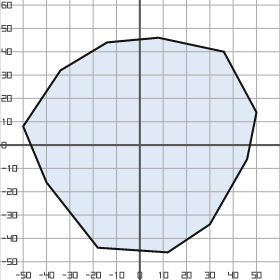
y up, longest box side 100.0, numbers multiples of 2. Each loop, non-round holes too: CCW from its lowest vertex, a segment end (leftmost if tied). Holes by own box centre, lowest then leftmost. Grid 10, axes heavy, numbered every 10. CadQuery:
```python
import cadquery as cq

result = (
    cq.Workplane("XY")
    .moveTo(12.0, -46.0)
    .lineTo(30.0, -34.0)
    .lineTo(46.0, -6.0)
    .lineTo(50.0, 14.0)
    .lineTo(36.0, 40.0)
    .lineTo(8.0, 46.0)
    .lineTo(-14.0, 44.0)
    .lineTo(-34.0, 32.0)
    .lineTo(-50.0, 8.0)
    .lineTo(-40.0, -16.0)
    .lineTo(-18.0, -44.0)
    .close()
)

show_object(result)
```